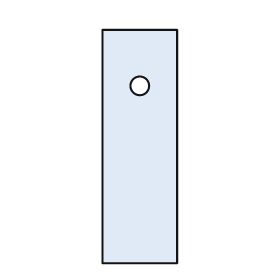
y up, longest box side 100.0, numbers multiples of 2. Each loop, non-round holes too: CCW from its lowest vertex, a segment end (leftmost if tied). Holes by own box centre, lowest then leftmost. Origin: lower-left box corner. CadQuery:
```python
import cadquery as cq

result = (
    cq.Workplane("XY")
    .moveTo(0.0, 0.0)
    .lineTo(32.0, 0.0)
    .lineTo(32.0, 100.0)
    .lineTo(0.0, 100.0)
    .close()
    .moveTo(16.0, 76.0)
    .circle(4.0)
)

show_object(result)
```